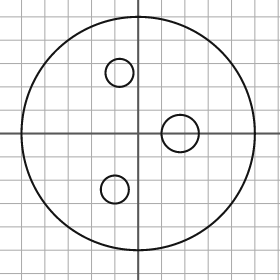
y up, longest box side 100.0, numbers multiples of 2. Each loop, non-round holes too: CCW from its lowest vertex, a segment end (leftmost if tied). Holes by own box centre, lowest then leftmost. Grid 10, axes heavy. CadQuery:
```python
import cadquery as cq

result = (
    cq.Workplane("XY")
    .moveTo(0.0, 0.0)
    .circle(50.0)
    .moveTo(-10.0, -24.0)
    .circle(6.0)
    .moveTo(18.0, 0.0)
    .circle(8.0)
    .moveTo(-8.0, 26.0)
    .circle(6.0)
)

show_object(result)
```